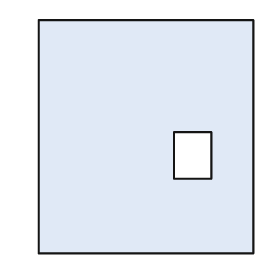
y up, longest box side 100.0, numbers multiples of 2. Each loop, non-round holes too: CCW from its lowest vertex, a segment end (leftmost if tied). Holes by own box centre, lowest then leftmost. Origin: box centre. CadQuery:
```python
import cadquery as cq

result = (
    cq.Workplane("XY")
    .moveTo(-46.0, -50.0)
    .lineTo(46.0, -50.0)
    .lineTo(46.0, 50.0)
    .lineTo(-46.0, 50.0)
    .close()
    .moveTo(12.0, -18.0)
    .lineTo(28.0, -18.0)
    .lineTo(28.0, 2.0)
    .lineTo(12.0, 2.0)
    .close()
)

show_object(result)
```